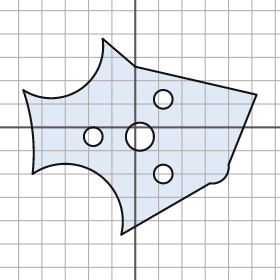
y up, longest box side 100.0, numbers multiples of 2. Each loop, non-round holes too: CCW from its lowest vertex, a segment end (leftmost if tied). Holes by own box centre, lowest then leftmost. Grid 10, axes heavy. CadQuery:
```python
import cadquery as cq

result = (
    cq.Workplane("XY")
    .moveTo(-6.0, -46.0)
    .lineTo(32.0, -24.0)
    .threePointArc((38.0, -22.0), (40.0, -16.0))
    .lineTo(52.0, 14.0)
    .lineTo(0.0, 26.0)
    .lineTo(-14.0, 38.0)
    .threePointArc((-24.0, 16.0), (-48.0, 16.0))
    .threePointArc((-44.0, -2.0), (-44.0, -20.0))
    .threePointArc((-16.0, -20.0), (-6.0, -46.0))
    .close()
    .moveTo(12.0, -20.0)
    .circle(4.0)
    .moveTo(-18.0, -4.0)
    .circle(4.0)
    .moveTo(2.0, -4.0)
    .circle(6.0)
    .moveTo(12.0, 12.0)
    .circle(4.0)
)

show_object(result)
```